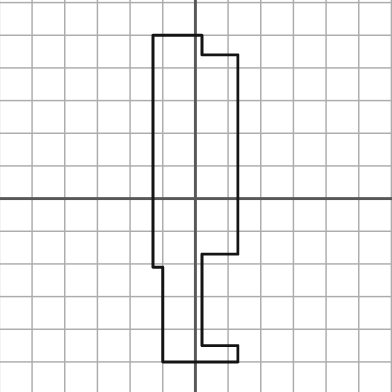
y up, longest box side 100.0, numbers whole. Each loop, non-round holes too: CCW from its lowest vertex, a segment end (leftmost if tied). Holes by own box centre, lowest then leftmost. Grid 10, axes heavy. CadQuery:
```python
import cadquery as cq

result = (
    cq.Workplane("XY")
    .moveTo(-10.0, -50.0)
    .lineTo(13.0, -50.0)
    .lineTo(13.0, -45.0)
    .lineTo(2.0, -45.0)
    .lineTo(2.0, -17.0)
    .lineTo(13.0, -17.0)
    .lineTo(13.0, 44.0)
    .lineTo(2.0, 44.0)
    .lineTo(2.0, 50.0)
    .lineTo(-13.0, 50.0)
    .lineTo(-13.0, -21.0)
    .lineTo(-10.0, -21.0)
    .close()
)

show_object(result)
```